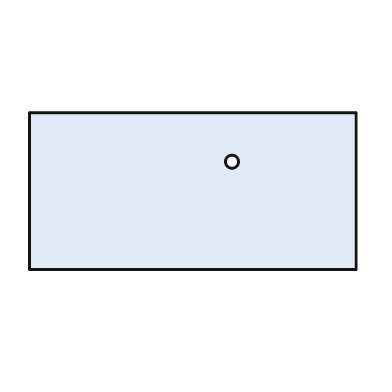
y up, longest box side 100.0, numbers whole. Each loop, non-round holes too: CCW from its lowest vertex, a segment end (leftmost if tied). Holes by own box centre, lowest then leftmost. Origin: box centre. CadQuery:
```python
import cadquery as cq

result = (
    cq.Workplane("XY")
    .moveTo(-50.0, -24.0)
    .lineTo(50.0, -24.0)
    .lineTo(50.0, 24.0)
    .lineTo(-50.0, 24.0)
    .close()
    .moveTo(12.0, 9.0)
    .circle(2.0)
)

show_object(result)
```